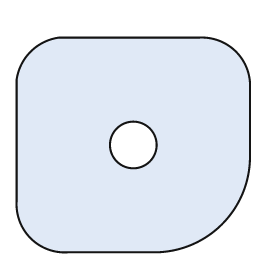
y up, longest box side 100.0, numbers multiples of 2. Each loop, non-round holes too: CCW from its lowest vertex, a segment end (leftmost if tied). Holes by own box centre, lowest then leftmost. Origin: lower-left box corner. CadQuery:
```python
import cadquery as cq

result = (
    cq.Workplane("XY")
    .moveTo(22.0, 0.0)
    .lineTo(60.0, 0.0)
    .threePointArc((88.0, 12.0), (100.0, 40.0))
    .lineTo(100.0, 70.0)
    .threePointArc((94.0, 86.0), (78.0, 92.0))
    .lineTo(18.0, 92.0)
    .threePointArc((6.0, 86.0), (0.0, 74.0))
    .lineTo(0.0, 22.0)
    .threePointArc((6.0, 6.0), (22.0, 0.0))
    .close()
    .moveTo(50.0, 46.0)
    .circle(10.0)
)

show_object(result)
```